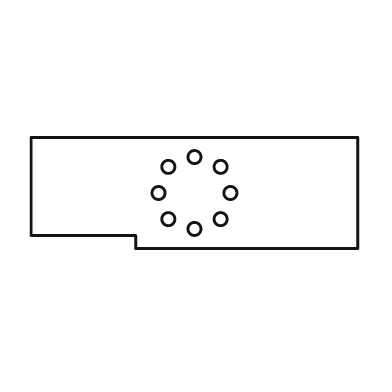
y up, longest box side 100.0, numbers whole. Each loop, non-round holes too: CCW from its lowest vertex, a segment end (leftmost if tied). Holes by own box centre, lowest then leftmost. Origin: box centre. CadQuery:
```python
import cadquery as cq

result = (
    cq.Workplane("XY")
    .moveTo(-18.0, -17.0)
    .lineTo(50.0, -17.0)
    .lineTo(50.0, 17.0)
    .lineTo(-50.0, 17.0)
    .lineTo(-50.0, -13.0)
    .lineTo(-18.0, -13.0)
    .close()
    .moveTo(0.0, -11.0)
    .circle(2.0)
    .moveTo(-8.0, -8.0)
    .circle(2.0)
    .moveTo(8.0, -8.0)
    .circle(2.0)
    .moveTo(-11.0, 0.0)
    .circle(2.0)
    .moveTo(11.0, 0.0)
    .circle(2.0)
    .moveTo(-8.0, 8.0)
    .circle(2.0)
    .moveTo(8.0, 8.0)
    .circle(2.0)
    .moveTo(0.0, 11.0)
    .circle(2.0)
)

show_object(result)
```